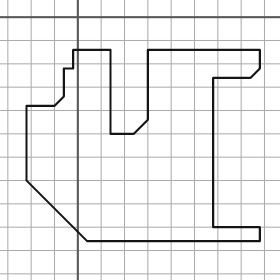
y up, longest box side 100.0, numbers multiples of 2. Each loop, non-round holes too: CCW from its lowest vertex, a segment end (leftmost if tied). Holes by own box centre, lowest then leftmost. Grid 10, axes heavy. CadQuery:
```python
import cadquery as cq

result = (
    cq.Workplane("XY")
    .moveTo(4.0, -96.0)
    .lineTo(78.0, -96.0)
    .lineTo(78.0, -90.0)
    .lineTo(58.0, -90.0)
    .lineTo(58.0, -26.0)
    .lineTo(74.0, -26.0)
    .lineTo(78.0, -22.0)
    .lineTo(78.0, -14.0)
    .lineTo(30.0, -14.0)
    .lineTo(30.0, -44.0)
    .lineTo(24.0, -50.0)
    .lineTo(14.0, -50.0)
    .lineTo(14.0, -14.0)
    .lineTo(-2.0, -14.0)
    .lineTo(-2.0, -22.0)
    .lineTo(-6.0, -22.0)
    .lineTo(-6.0, -34.0)
    .lineTo(-10.0, -38.0)
    .lineTo(-22.0, -38.0)
    .lineTo(-22.0, -70.0)
    .close()
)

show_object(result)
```